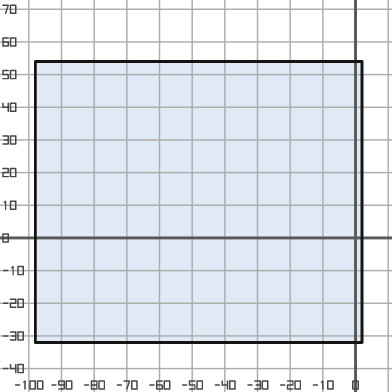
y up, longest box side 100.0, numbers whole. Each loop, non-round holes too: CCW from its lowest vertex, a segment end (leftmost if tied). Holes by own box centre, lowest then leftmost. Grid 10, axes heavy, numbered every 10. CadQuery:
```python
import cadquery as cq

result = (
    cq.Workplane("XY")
    .moveTo(-98.0, -32.0)
    .lineTo(2.0, -32.0)
    .lineTo(2.0, 54.0)
    .lineTo(-98.0, 54.0)
    .close()
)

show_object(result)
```